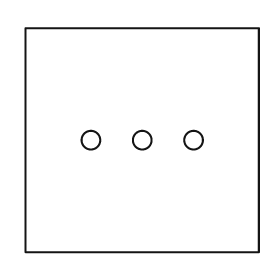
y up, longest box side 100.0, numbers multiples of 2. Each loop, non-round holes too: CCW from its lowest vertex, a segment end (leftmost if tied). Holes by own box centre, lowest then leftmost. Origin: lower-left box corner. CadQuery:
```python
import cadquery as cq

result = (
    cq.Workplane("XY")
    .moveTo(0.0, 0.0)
    .lineTo(100.0, 0.0)
    .lineTo(100.0, 96.0)
    .lineTo(0.0, 96.0)
    .close()
    .moveTo(28.0, 48.0)
    .circle(4.0)
    .moveTo(50.0, 48.0)
    .circle(4.0)
    .moveTo(72.0, 48.0)
    .circle(4.0)
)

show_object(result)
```